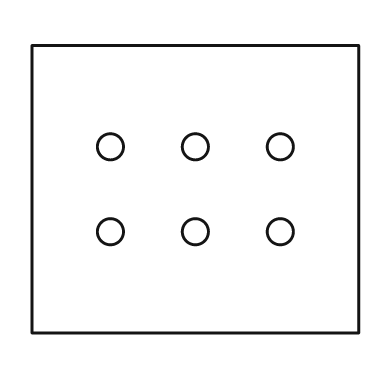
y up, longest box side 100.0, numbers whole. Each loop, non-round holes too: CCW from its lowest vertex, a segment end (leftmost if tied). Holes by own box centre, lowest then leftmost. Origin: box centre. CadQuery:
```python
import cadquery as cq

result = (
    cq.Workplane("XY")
    .moveTo(-50.0, -44.0)
    .lineTo(50.0, -44.0)
    .lineTo(50.0, 44.0)
    .lineTo(-50.0, 44.0)
    .close()
    .moveTo(-26.0, -13.0)
    .circle(4.0)
    .moveTo(0.0, -13.0)
    .circle(4.0)
    .moveTo(26.0, -13.0)
    .circle(4.0)
    .moveTo(-26.0, 13.0)
    .circle(4.0)
    .moveTo(0.0, 13.0)
    .circle(4.0)
    .moveTo(26.0, 13.0)
    .circle(4.0)
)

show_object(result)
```